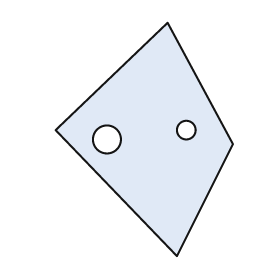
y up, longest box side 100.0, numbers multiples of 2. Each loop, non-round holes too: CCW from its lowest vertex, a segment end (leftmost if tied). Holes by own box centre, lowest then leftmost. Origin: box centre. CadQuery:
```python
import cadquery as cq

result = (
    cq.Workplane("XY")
    .moveTo(14.0, -50.0)
    .lineTo(38.0, -2.0)
    .lineTo(10.0, 50.0)
    .lineTo(-38.0, 4.0)
    .close()
    .moveTo(-16.0, 0.0)
    .circle(6.0)
    .moveTo(18.0, 4.0)
    .circle(4.0)
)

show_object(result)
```